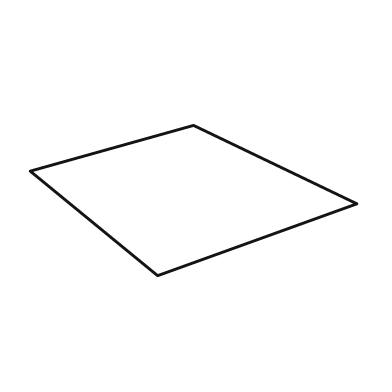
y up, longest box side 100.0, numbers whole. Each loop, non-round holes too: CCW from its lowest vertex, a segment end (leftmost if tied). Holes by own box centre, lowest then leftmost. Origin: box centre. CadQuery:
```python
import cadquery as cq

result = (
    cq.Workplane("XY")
    .moveTo(-11.0, -23.0)
    .lineTo(50.0, -1.0)
    .lineTo(0.0, 23.0)
    .lineTo(-50.0, 9.0)
    .close()
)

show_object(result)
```